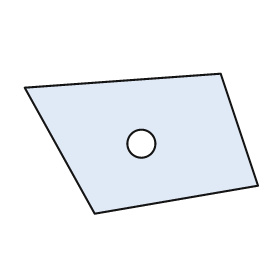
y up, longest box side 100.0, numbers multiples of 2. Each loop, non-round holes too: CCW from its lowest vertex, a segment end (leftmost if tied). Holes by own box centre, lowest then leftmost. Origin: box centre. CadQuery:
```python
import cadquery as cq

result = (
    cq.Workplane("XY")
    .moveTo(-20.0, -30.0)
    .lineTo(50.0, -18.0)
    .lineTo(34.0, 30.0)
    .lineTo(-50.0, 24.0)
    .close()
    .moveTo(0.0, 0.0)
    .circle(6.0)
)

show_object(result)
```